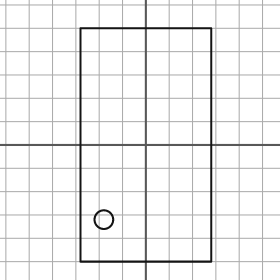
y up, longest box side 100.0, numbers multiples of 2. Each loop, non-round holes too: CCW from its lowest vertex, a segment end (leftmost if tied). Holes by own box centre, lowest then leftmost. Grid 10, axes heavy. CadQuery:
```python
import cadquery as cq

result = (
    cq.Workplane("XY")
    .moveTo(-28.0, -50.0)
    .lineTo(28.0, -50.0)
    .lineTo(28.0, 50.0)
    .lineTo(-28.0, 50.0)
    .close()
    .moveTo(-18.0, -32.0)
    .circle(4.0)
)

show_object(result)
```